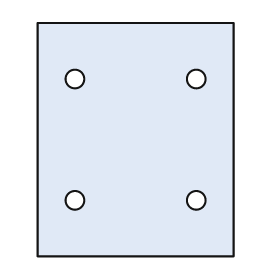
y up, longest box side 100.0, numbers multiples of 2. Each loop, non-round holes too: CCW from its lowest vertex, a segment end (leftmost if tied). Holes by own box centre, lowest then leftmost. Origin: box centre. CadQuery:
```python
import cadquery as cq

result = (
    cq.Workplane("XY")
    .moveTo(-42.0, -50.0)
    .lineTo(42.0, -50.0)
    .lineTo(42.0, 50.0)
    .lineTo(-42.0, 50.0)
    .close()
    .moveTo(-26.0, -26.0)
    .circle(4.0)
    .moveTo(26.0, -26.0)
    .circle(4.0)
    .moveTo(-26.0, 26.0)
    .circle(4.0)
    .moveTo(26.0, 26.0)
    .circle(4.0)
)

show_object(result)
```